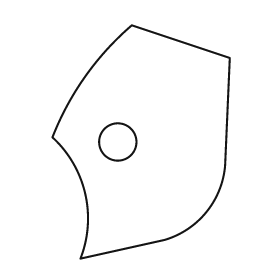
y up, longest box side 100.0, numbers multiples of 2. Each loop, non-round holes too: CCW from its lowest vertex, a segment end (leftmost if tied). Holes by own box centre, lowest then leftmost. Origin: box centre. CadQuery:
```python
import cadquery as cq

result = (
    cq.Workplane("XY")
    .moveTo(-26.0, -50.0)
    .lineTo(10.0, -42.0)
    .threePointArc((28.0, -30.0), (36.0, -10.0))
    .lineTo(38.0, 36.0)
    .lineTo(-4.0, 50.0)
    .threePointArc((-24.0, 28.0), (-38.0, 2.0))
    .threePointArc((-24.0, -22.0), (-26.0, -50.0))
    .close()
    .moveTo(-10.0, 0.0)
    .circle(8.0)
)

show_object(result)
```